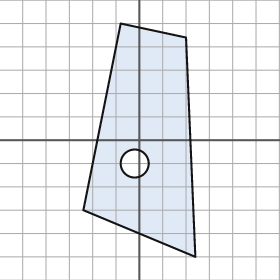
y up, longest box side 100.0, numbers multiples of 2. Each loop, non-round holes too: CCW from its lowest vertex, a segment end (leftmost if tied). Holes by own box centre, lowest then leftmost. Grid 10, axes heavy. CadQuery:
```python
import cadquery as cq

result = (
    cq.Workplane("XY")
    .moveTo(24.0, -50.0)
    .lineTo(20.0, 44.0)
    .lineTo(-8.0, 50.0)
    .lineTo(-24.0, -30.0)
    .close()
    .moveTo(-2.0, -10.0)
    .circle(6.0)
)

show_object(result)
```